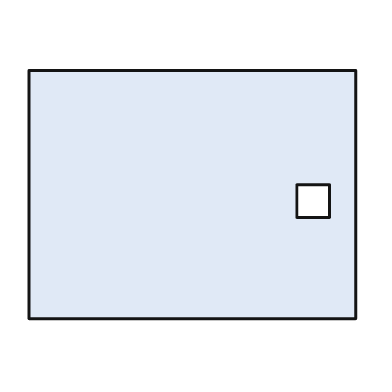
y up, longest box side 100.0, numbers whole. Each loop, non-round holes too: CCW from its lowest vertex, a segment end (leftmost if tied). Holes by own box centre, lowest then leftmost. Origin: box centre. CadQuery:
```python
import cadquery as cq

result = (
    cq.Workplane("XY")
    .moveTo(-50.0, -38.0)
    .lineTo(50.0, -38.0)
    .lineTo(50.0, 38.0)
    .lineTo(-50.0, 38.0)
    .close()
    .moveTo(32.0, -7.0)
    .lineTo(42.0, -7.0)
    .lineTo(42.0, 3.0)
    .lineTo(32.0, 3.0)
    .close()
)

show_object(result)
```